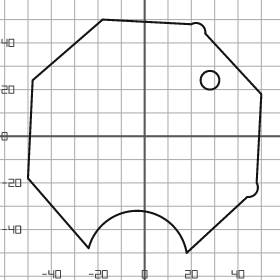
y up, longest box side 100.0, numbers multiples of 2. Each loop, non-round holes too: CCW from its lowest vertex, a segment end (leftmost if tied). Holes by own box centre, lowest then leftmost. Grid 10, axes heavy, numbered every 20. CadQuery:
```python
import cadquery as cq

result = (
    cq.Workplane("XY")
    .moveTo(18.0, -50.0)
    .lineTo(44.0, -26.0)
    .threePointArc((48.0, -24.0), (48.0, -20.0))
    .lineTo(50.0, 18.0)
    .lineTo(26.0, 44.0)
    .threePointArc((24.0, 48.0), (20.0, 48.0))
    .lineTo(-18.0, 50.0)
    .lineTo(-48.0, 24.0)
    .lineTo(-50.0, -18.0)
    .lineTo(-24.0, -48.0)
    .threePointArc((-2.0, -32.0), (18.0, -50.0))
    .close()
    .moveTo(28.0, 24.0)
    .circle(4.0)
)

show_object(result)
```